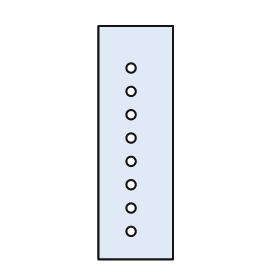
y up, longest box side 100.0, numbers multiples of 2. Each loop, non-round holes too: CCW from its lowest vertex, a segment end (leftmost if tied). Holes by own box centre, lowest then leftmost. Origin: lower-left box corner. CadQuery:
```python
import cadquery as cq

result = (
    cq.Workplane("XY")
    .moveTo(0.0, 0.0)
    .lineTo(32.0, 0.0)
    .lineTo(32.0, 100.0)
    .lineTo(0.0, 100.0)
    .close()
    .moveTo(14.0, 12.0)
    .circle(2.0)
    .moveTo(14.0, 22.0)
    .circle(2.0)
    .moveTo(14.0, 32.0)
    .circle(2.0)
    .moveTo(14.0, 42.0)
    .circle(2.0)
    .moveTo(14.0, 52.0)
    .circle(2.0)
    .moveTo(14.0, 62.0)
    .circle(2.0)
    .moveTo(14.0, 72.0)
    .circle(2.0)
    .moveTo(14.0, 82.0)
    .circle(2.0)
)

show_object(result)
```